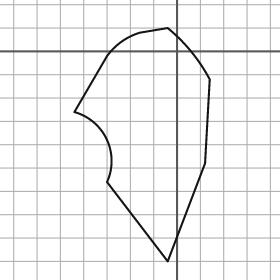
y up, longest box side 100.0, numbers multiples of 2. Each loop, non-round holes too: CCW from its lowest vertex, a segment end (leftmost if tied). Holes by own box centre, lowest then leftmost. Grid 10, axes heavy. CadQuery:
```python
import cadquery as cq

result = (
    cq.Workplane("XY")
    .moveTo(-4.0, -90.0)
    .lineTo(12.0, -48.0)
    .lineTo(14.0, -12.0)
    .threePointArc((6.0, 0.0), (-4.0, 10.0))
    .lineTo(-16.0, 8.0)
    .threePointArc((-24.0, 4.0), (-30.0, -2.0))
    .lineTo(-44.0, -26.0)
    .threePointArc((-30.0, -38.0), (-30.0, -56.0))
    .close()
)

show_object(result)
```